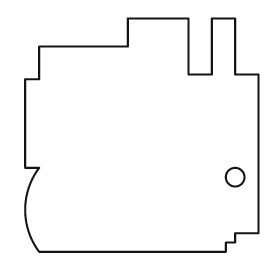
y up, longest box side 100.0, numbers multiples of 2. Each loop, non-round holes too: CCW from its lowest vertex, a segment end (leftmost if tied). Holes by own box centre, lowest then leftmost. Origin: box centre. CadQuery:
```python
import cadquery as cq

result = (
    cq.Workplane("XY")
    .moveTo(-44.0, -50.0)
    .lineTo(36.0, -50.0)
    .lineTo(36.0, -46.0)
    .lineTo(40.0, -46.0)
    .lineTo(40.0, -42.0)
    .lineTo(50.0, -42.0)
    .lineTo(50.0, 26.0)
    .lineTo(40.0, 26.0)
    .lineTo(40.0, 50.0)
    .lineTo(30.0, 50.0)
    .lineTo(30.0, 26.0)
    .lineTo(20.0, 26.0)
    .lineTo(20.0, 50.0)
    .lineTo(-6.0, 50.0)
    .lineTo(-6.0, 38.0)
    .lineTo(-44.0, 38.0)
    .lineTo(-44.0, 24.0)
    .lineTo(-50.0, 24.0)
    .lineTo(-50.0, -14.0)
    .lineTo(-44.0, -14.0)
    .threePointArc((-50.0, -32.0), (-44.0, -50.0))
    .close()
    .moveTo(40.0, -18.0)
    .circle(4.0)
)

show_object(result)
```